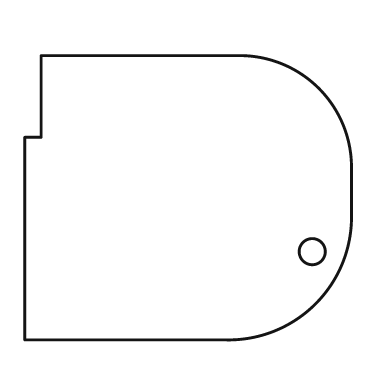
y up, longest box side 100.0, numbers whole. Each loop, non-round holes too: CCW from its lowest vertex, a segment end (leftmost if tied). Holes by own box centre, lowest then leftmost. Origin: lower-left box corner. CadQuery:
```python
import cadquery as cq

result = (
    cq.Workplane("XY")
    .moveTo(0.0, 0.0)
    .lineTo(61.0, 0.0)
    .threePointArc((89.0, 11.0), (100.0, 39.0))
    .lineTo(100.0, 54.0)
    .threePointArc((90.0, 77.0), (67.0, 87.0))
    .lineTo(5.0, 87.0)
    .lineTo(5.0, 62.0)
    .lineTo(0.0, 62.0)
    .close()
    .moveTo(88.0, 27.0)
    .circle(4.0)
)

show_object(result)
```